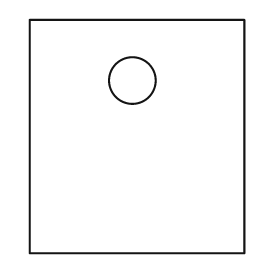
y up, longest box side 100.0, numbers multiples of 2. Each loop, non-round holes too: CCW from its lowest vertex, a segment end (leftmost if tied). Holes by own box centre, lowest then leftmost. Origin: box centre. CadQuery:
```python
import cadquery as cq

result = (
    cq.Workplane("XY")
    .moveTo(-46.0, -50.0)
    .lineTo(46.0, -50.0)
    .lineTo(46.0, 50.0)
    .lineTo(-46.0, 50.0)
    .close()
    .moveTo(-2.0, 24.0)
    .circle(10.0)
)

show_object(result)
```